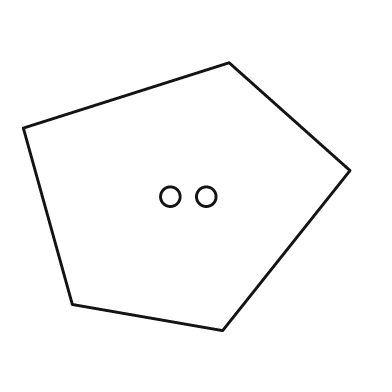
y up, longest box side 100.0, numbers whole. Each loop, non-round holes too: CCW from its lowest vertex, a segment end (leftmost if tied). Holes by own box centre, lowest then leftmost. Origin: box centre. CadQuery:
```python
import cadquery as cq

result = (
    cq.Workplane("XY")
    .moveTo(11.0, -41.0)
    .lineTo(50.0, 8.0)
    .lineTo(13.0, 41.0)
    .lineTo(-50.0, 21.0)
    .lineTo(-35.0, -33.0)
    .close()
    .moveTo(-5.0, 0.0)
    .circle(3.0)
    .moveTo(6.0, 0.0)
    .circle(3.0)
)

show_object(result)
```